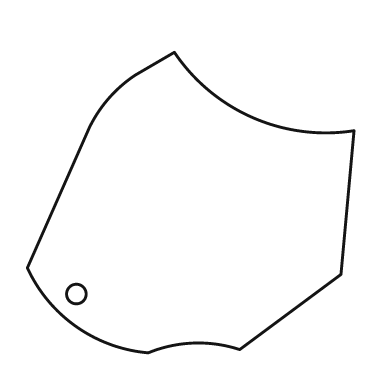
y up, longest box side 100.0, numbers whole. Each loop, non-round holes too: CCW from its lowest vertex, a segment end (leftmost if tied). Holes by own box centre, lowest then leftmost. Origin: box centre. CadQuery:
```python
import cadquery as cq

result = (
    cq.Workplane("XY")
    .moveTo(-13.0, -46.0)
    .threePointArc((1.0, -43.0), (15.0, -45.0))
    .lineTo(46.0, -22.0)
    .lineTo(50.0, 22.0)
    .threePointArc((19.0, 26.0), (-5.0, 46.0))
    .lineTo(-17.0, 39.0)
    .threePointArc((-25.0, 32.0), (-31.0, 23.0))
    .lineTo(-50.0, -20.0)
    .threePointArc((-35.0, -38.0), (-13.0, -46.0))
    .close()
    .moveTo(-35.0, -28.0)
    .circle(3.0)
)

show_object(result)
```